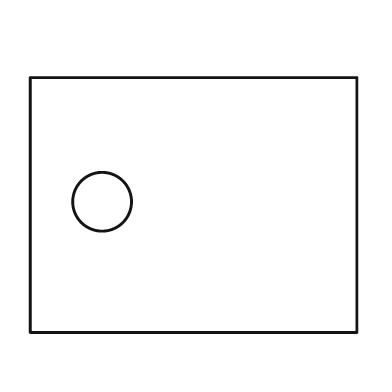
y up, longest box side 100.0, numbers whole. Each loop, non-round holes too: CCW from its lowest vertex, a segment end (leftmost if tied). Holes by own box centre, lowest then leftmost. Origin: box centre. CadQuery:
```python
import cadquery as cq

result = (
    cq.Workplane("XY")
    .moveTo(-50.0, -39.0)
    .lineTo(50.0, -39.0)
    .lineTo(50.0, 39.0)
    .lineTo(-50.0, 39.0)
    .close()
    .moveTo(-28.0, 1.0)
    .circle(9.0)
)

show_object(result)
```